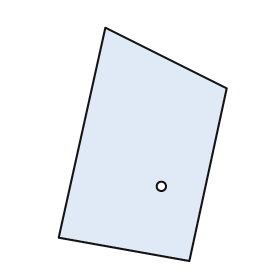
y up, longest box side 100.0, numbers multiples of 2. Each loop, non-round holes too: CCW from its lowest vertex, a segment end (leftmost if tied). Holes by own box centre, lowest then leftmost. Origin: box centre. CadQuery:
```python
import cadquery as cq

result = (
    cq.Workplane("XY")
    .moveTo(20.0, -50.0)
    .lineTo(36.0, 24.0)
    .lineTo(-16.0, 50.0)
    .lineTo(-36.0, -40.0)
    .close()
    .moveTo(8.0, -18.0)
    .circle(2.0)
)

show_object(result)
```